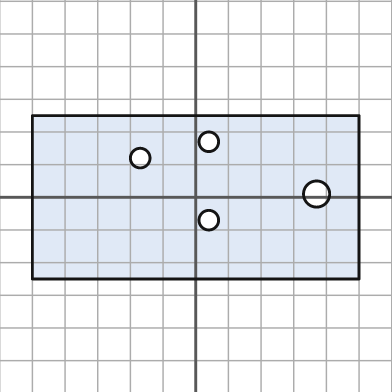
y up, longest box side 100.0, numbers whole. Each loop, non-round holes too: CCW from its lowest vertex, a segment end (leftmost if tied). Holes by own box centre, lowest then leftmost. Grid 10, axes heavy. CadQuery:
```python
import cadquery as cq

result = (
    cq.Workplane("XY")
    .moveTo(-50.0, -25.0)
    .lineTo(50.0, -25.0)
    .lineTo(50.0, 25.0)
    .lineTo(-50.0, 25.0)
    .close()
    .moveTo(4.0, -7.0)
    .circle(3.0)
    .moveTo(37.0, 1.0)
    .circle(4.0)
    .moveTo(-17.0, 12.0)
    .circle(3.0)
    .moveTo(4.0, 17.0)
    .circle(3.0)
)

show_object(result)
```